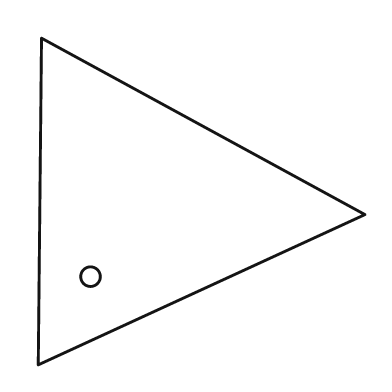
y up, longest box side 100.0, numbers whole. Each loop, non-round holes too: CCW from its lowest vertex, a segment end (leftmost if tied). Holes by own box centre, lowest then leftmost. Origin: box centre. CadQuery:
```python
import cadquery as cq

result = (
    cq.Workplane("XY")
    .moveTo(-50.0, -50.0)
    .lineTo(50.0, -4.0)
    .lineTo(-49.0, 50.0)
    .close()
    .moveTo(-34.0, -23.0)
    .circle(3.0)
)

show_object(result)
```